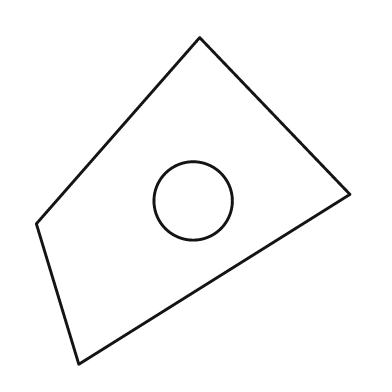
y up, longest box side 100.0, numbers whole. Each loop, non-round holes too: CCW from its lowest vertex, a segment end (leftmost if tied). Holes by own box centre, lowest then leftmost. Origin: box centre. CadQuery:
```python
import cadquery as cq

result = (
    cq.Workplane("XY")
    .moveTo(-35.0, -50.0)
    .lineTo(48.0, 2.0)
    .lineTo(2.0, 50.0)
    .lineTo(-48.0, -7.0)
    .close()
    .moveTo(0.0, 0.0)
    .circle(12.0)
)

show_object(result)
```